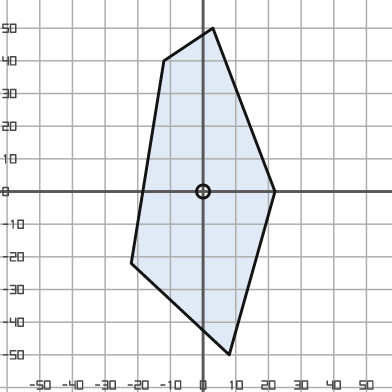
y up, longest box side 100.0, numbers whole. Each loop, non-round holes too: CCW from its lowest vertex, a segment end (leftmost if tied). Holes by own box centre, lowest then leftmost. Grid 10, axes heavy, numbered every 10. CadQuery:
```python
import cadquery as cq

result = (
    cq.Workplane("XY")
    .moveTo(8.0, -50.0)
    .lineTo(22.0, 0.0)
    .lineTo(3.0, 50.0)
    .lineTo(-12.0, 40.0)
    .lineTo(-22.0, -22.0)
    .close()
    .moveTo(0.0, 0.0)
    .circle(2.0)
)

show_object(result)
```